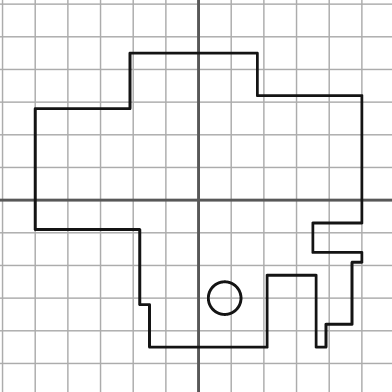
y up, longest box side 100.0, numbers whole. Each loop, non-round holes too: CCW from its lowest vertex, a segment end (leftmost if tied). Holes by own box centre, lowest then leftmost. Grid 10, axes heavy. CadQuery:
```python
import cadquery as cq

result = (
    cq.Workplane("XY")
    .moveTo(-15.0, -45.0)
    .lineTo(21.0, -45.0)
    .lineTo(21.0, -23.0)
    .lineTo(36.0, -23.0)
    .lineTo(36.0, -45.0)
    .lineTo(39.0, -45.0)
    .lineTo(39.0, -38.0)
    .lineTo(47.0, -38.0)
    .lineTo(47.0, -19.0)
    .lineTo(50.0, -19.0)
    .lineTo(50.0, -16.0)
    .lineTo(35.0, -16.0)
    .lineTo(35.0, -7.0)
    .lineTo(50.0, -7.0)
    .lineTo(50.0, 32.0)
    .lineTo(18.0, 32.0)
    .lineTo(18.0, 45.0)
    .lineTo(-21.0, 45.0)
    .lineTo(-21.0, 28.0)
    .lineTo(-50.0, 28.0)
    .lineTo(-50.0, -9.0)
    .lineTo(-18.0, -9.0)
    .lineTo(-18.0, -32.0)
    .lineTo(-15.0, -32.0)
    .close()
    .moveTo(8.0, -30.0)
    .circle(5.0)
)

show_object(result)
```